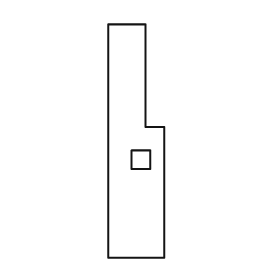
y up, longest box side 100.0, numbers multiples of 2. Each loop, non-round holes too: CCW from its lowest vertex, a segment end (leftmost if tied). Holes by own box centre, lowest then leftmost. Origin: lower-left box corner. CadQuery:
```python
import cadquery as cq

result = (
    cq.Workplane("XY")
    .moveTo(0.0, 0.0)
    .lineTo(24.0, 0.0)
    .lineTo(24.0, 56.0)
    .lineTo(16.0, 56.0)
    .lineTo(16.0, 100.0)
    .lineTo(0.0, 100.0)
    .close()
    .moveTo(10.0, 38.0)
    .lineTo(18.0, 38.0)
    .lineTo(18.0, 46.0)
    .lineTo(10.0, 46.0)
    .close()
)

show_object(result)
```